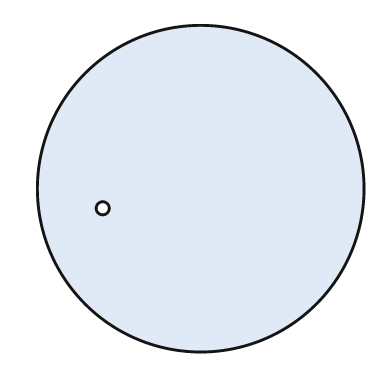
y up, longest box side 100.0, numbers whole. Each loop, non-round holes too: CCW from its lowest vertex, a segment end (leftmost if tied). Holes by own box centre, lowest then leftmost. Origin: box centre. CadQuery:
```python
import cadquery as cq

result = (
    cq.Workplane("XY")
    .moveTo(0.0, 0.0)
    .circle(50.0)
    .moveTo(-30.0, -6.0)
    .circle(2.0)
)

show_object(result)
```